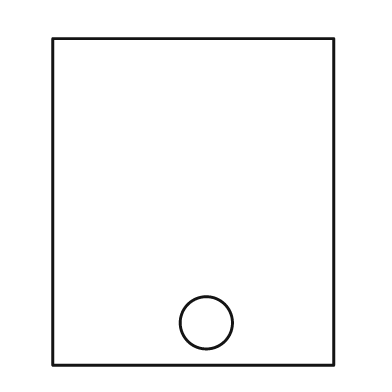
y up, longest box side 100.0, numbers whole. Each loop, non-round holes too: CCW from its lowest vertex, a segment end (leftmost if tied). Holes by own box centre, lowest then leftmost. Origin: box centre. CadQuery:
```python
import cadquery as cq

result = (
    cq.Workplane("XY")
    .moveTo(-43.0, -50.0)
    .lineTo(43.0, -50.0)
    .lineTo(43.0, 50.0)
    .lineTo(-43.0, 50.0)
    .close()
    .moveTo(4.0, -37.0)
    .circle(8.0)
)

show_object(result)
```